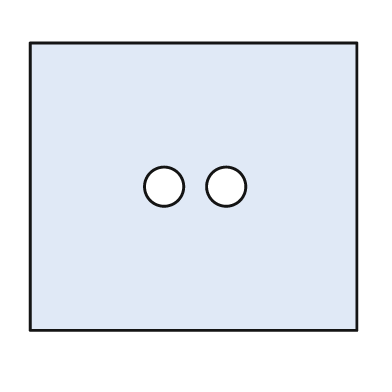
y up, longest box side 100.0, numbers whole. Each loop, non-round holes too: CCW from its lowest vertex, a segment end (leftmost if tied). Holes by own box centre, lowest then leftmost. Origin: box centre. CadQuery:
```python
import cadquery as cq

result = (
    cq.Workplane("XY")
    .moveTo(-50.0, -44.0)
    .lineTo(50.0, -44.0)
    .lineTo(50.0, 44.0)
    .lineTo(-50.0, 44.0)
    .close()
    .moveTo(-9.0, 0.0)
    .circle(6.0)
    .moveTo(10.0, 0.0)
    .circle(6.0)
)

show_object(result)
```